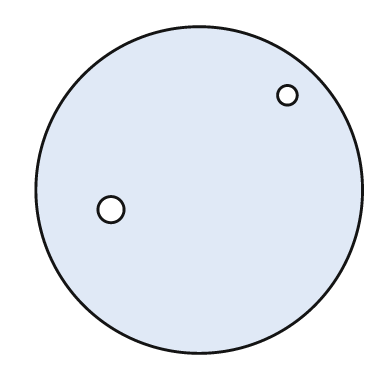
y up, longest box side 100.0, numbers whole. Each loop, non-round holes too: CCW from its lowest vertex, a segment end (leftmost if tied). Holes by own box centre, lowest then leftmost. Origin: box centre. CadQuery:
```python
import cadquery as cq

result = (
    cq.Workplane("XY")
    .moveTo(0.0, 0.0)
    .circle(50.0)
    .moveTo(-27.0, -6.0)
    .circle(4.0)
    .moveTo(27.0, 29.0)
    .circle(3.0)
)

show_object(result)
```